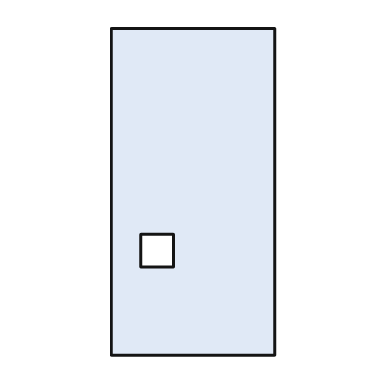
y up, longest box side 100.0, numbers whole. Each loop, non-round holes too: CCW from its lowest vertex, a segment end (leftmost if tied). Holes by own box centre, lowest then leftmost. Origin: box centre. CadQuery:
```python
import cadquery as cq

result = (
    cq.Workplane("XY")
    .moveTo(-25.0, -50.0)
    .lineTo(25.0, -50.0)
    .lineTo(25.0, 50.0)
    .lineTo(-25.0, 50.0)
    .close()
    .moveTo(-16.0, -23.0)
    .lineTo(-6.0, -23.0)
    .lineTo(-6.0, -13.0)
    .lineTo(-16.0, -13.0)
    .close()
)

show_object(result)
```